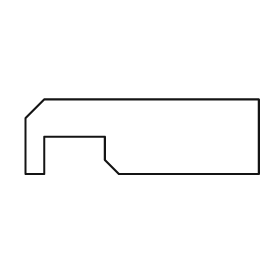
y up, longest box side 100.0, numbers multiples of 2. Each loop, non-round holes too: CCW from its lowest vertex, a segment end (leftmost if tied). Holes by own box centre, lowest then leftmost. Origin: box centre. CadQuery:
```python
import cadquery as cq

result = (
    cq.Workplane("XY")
    .moveTo(-50.0, -16.0)
    .lineTo(-42.0, -16.0)
    .lineTo(-42.0, 0.0)
    .lineTo(-16.0, 0.0)
    .lineTo(-16.0, -10.0)
    .lineTo(-10.0, -16.0)
    .lineTo(50.0, -16.0)
    .lineTo(50.0, 16.0)
    .lineTo(-42.0, 16.0)
    .lineTo(-50.0, 8.0)
    .close()
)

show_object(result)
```